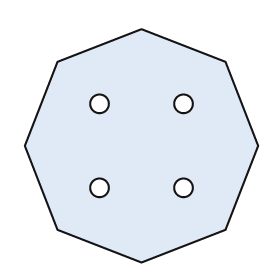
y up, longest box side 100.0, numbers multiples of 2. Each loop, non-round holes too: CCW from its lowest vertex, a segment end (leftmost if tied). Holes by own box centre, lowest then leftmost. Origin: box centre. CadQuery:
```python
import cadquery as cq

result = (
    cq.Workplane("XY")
    .moveTo(0.0, -50.0)
    .lineTo(36.0, -36.0)
    .lineTo(50.0, 0.0)
    .lineTo(36.0, 36.0)
    .lineTo(0.0, 50.0)
    .lineTo(-36.0, 36.0)
    .lineTo(-50.0, 0.0)
    .lineTo(-36.0, -36.0)
    .close()
    .moveTo(-18.0, -18.0)
    .circle(4.0)
    .moveTo(18.0, -18.0)
    .circle(4.0)
    .moveTo(-18.0, 18.0)
    .circle(4.0)
    .moveTo(18.0, 18.0)
    .circle(4.0)
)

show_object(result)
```